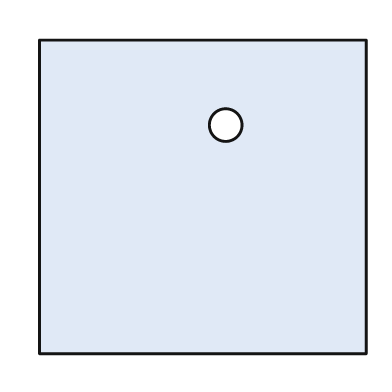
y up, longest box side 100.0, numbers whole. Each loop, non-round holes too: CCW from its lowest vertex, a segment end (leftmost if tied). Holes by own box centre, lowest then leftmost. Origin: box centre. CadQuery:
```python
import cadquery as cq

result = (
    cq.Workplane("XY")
    .moveTo(-50.0, -48.0)
    .lineTo(50.0, -48.0)
    .lineTo(50.0, 48.0)
    .lineTo(-50.0, 48.0)
    .close()
    .moveTo(7.0, 22.0)
    .circle(5.0)
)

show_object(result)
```